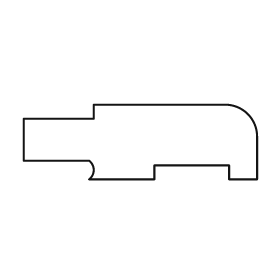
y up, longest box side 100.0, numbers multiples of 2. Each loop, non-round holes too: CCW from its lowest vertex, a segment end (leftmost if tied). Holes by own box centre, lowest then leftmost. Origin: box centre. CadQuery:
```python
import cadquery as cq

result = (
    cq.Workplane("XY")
    .moveTo(-22.0, -16.0)
    .lineTo(6.0, -16.0)
    .lineTo(6.0, -10.0)
    .lineTo(38.0, -10.0)
    .lineTo(38.0, -16.0)
    .lineTo(50.0, -16.0)
    .lineTo(50.0, 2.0)
    .threePointArc((46.0, 12.0), (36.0, 16.0))
    .lineTo(-20.0, 16.0)
    .lineTo(-20.0, 10.0)
    .lineTo(-50.0, 10.0)
    .lineTo(-50.0, -8.0)
    .lineTo(-22.0, -8.0)
    .threePointArc((-20.0, -12.0), (-22.0, -16.0))
    .close()
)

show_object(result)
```